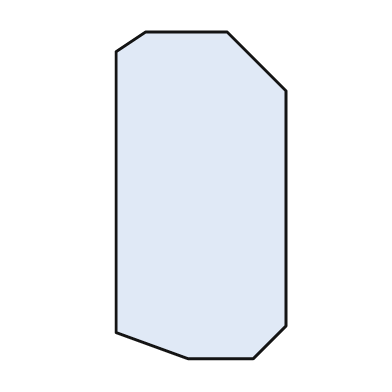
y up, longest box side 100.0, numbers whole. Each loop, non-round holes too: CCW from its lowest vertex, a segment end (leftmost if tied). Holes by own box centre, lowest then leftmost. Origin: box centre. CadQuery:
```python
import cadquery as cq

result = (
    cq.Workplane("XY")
    .moveTo(-4.0, -50.0)
    .lineTo(16.0, -50.0)
    .lineTo(26.0, -40.0)
    .lineTo(26.0, 32.0)
    .lineTo(8.0, 50.0)
    .lineTo(-17.0, 50.0)
    .lineTo(-26.0, 44.0)
    .lineTo(-26.0, -42.0)
    .close()
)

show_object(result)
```